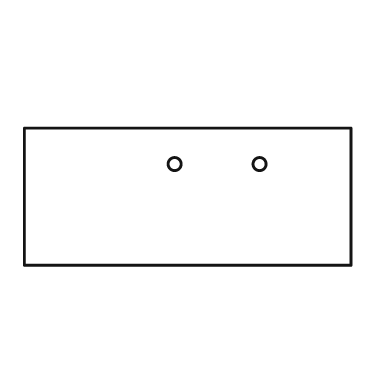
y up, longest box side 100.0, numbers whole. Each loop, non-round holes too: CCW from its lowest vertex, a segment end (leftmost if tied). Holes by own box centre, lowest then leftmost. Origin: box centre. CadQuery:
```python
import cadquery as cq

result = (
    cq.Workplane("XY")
    .moveTo(-50.0, -21.0)
    .lineTo(50.0, -21.0)
    .lineTo(50.0, 21.0)
    .lineTo(-50.0, 21.0)
    .close()
    .moveTo(-4.0, 10.0)
    .circle(2.0)
    .moveTo(22.0, 10.0)
    .circle(2.0)
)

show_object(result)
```